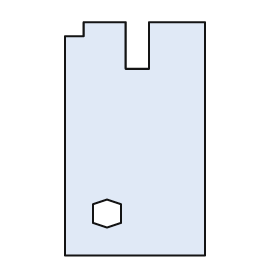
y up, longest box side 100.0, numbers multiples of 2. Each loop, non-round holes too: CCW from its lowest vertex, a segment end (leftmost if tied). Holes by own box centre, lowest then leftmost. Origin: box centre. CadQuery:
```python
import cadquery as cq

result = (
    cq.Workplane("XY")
    .moveTo(-30.0, -50.0)
    .lineTo(30.0, -50.0)
    .lineTo(30.0, 50.0)
    .lineTo(6.0, 50.0)
    .lineTo(6.0, 30.0)
    .lineTo(-4.0, 30.0)
    .lineTo(-4.0, 50.0)
    .lineTo(-22.0, 50.0)
    .lineTo(-22.0, 44.0)
    .lineTo(-30.0, 44.0)
    .close()
    .moveTo(-12.0, -38.0)
    .lineTo(-6.0, -36.0)
    .lineTo(-6.0, -28.0)
    .lineTo(-12.0, -26.0)
    .lineTo(-18.0, -28.0)
    .lineTo(-18.0, -36.0)
    .close()
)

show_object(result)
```